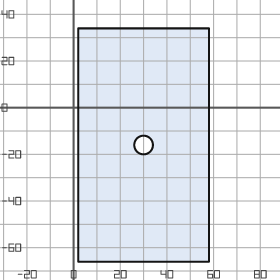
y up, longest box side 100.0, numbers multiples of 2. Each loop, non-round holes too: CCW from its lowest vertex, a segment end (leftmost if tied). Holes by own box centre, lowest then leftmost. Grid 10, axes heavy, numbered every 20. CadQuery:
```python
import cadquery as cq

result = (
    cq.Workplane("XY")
    .moveTo(2.0, -66.0)
    .lineTo(58.0, -66.0)
    .lineTo(58.0, 34.0)
    .lineTo(2.0, 34.0)
    .close()
    .moveTo(30.0, -16.0)
    .circle(4.0)
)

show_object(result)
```